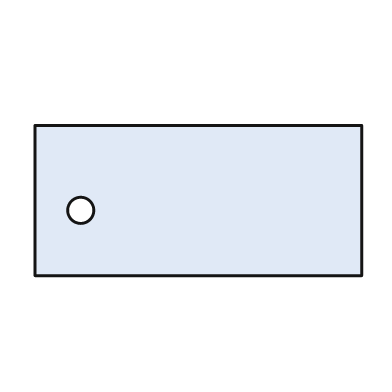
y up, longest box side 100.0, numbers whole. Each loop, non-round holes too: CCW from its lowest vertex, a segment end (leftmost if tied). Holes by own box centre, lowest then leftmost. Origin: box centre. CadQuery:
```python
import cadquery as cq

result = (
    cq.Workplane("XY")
    .moveTo(-50.0, -23.0)
    .lineTo(50.0, -23.0)
    .lineTo(50.0, 23.0)
    .lineTo(-50.0, 23.0)
    .close()
    .moveTo(-36.0, -3.0)
    .circle(4.0)
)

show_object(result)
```